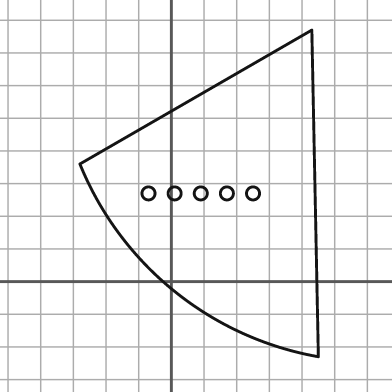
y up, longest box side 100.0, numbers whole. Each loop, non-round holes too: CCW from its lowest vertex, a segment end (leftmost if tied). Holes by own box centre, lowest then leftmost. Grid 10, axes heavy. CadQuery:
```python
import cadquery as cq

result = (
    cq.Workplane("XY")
    .moveTo(45.0, -23.0)
    .lineTo(43.0, 77.0)
    .lineTo(-28.0, 36.0)
    .threePointArc((1.0, -3.0), (45.0, -23.0))
    .close()
    .moveTo(-7.0, 27.0)
    .circle(2.0)
    .moveTo(1.0, 27.0)
    .circle(2.0)
    .moveTo(9.0, 27.0)
    .circle(2.0)
    .moveTo(17.0, 27.0)
    .circle(2.0)
    .moveTo(25.0, 27.0)
    .circle(2.0)
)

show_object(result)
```